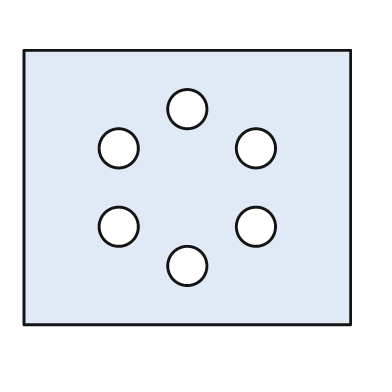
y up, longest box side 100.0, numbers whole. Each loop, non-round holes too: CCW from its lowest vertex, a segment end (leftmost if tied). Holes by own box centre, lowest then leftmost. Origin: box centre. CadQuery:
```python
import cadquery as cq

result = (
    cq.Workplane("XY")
    .moveTo(-50.0, -42.0)
    .lineTo(50.0, -42.0)
    .lineTo(50.0, 42.0)
    .lineTo(-50.0, 42.0)
    .close()
    .moveTo(0.0, -24.0)
    .circle(6.0)
    .moveTo(-21.0, -12.0)
    .circle(6.0)
    .moveTo(21.0, -12.0)
    .circle(6.0)
    .moveTo(-21.0, 12.0)
    .circle(6.0)
    .moveTo(21.0, 12.0)
    .circle(6.0)
    .moveTo(0.0, 24.0)
    .circle(6.0)
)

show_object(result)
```